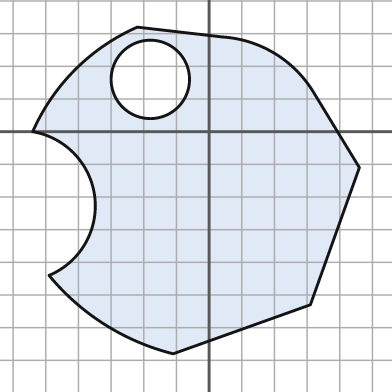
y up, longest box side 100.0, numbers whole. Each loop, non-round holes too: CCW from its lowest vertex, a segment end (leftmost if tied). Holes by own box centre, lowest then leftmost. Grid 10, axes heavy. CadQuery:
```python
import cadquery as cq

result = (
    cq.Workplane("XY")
    .moveTo(-11.0, -68.0)
    .lineTo(31.0, -53.0)
    .lineTo(46.0, -11.0)
    .lineTo(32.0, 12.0)
    .threePointArc((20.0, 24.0), (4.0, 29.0))
    .lineTo(-22.0, 32.0)
    .threePointArc((-41.0, 19.0), (-54.0, 0.0))
    .threePointArc((-35.0, -20.0), (-49.0, -44.0))
    .threePointArc((-32.0, -59.0), (-11.0, -68.0))
    .close()
    .moveTo(-18.0, 16.0)
    .circle(12.0)
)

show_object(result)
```